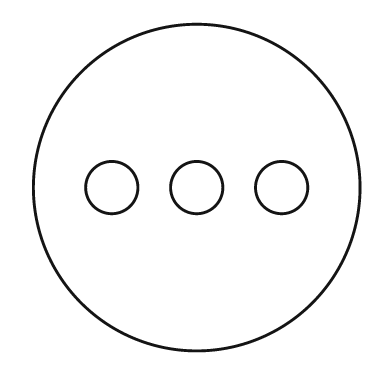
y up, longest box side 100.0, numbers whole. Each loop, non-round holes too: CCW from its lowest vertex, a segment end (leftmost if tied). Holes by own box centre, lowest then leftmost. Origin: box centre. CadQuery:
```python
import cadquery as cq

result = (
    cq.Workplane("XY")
    .moveTo(0.0, 0.0)
    .circle(50.0)
    .moveTo(-26.0, 0.0)
    .circle(8.0)
    .moveTo(0.0, 0.0)
    .circle(8.0)
    .moveTo(26.0, 0.0)
    .circle(8.0)
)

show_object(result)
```